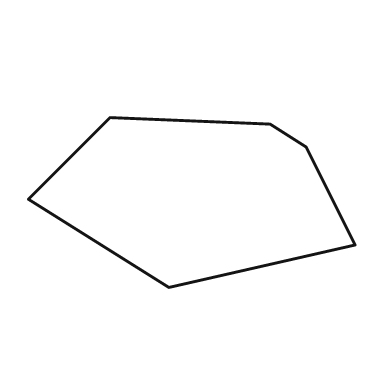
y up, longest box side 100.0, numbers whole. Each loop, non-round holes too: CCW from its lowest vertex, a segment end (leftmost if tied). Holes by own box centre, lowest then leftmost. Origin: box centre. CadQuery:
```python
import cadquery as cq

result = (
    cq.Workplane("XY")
    .moveTo(-7.0, -26.0)
    .lineTo(50.0, -13.0)
    .lineTo(35.0, 17.0)
    .lineTo(24.0, 24.0)
    .lineTo(-25.0, 26.0)
    .lineTo(-50.0, 1.0)
    .close()
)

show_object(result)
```